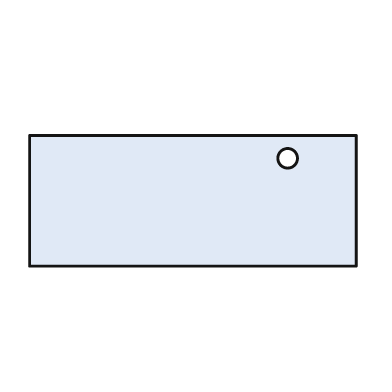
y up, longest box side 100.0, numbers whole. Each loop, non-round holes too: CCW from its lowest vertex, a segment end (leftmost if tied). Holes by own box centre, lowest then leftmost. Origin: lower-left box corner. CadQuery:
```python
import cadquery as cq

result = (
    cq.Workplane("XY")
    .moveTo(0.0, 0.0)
    .lineTo(100.0, 0.0)
    .lineTo(100.0, 40.0)
    .lineTo(0.0, 40.0)
    .close()
    .moveTo(79.0, 33.0)
    .circle(3.0)
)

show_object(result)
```